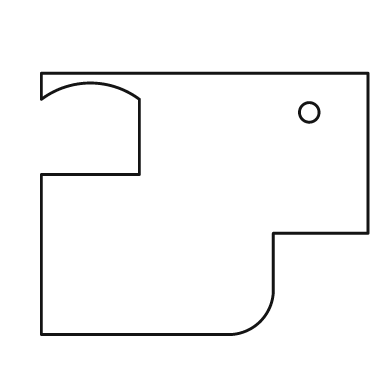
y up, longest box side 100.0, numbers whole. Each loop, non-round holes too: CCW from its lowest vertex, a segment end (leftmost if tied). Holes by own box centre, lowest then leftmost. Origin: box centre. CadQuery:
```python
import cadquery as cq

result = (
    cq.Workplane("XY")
    .moveTo(-50.0, -40.0)
    .lineTo(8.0, -40.0)
    .threePointArc((17.0, -36.0), (21.0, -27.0))
    .lineTo(21.0, -9.0)
    .lineTo(50.0, -9.0)
    .lineTo(50.0, 40.0)
    .lineTo(-50.0, 40.0)
    .lineTo(-50.0, 32.0)
    .threePointArc((-35.0, 37.0), (-20.0, 32.0))
    .lineTo(-20.0, 9.0)
    .lineTo(-50.0, 9.0)
    .close()
    .moveTo(32.0, 28.0)
    .circle(3.0)
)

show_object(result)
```